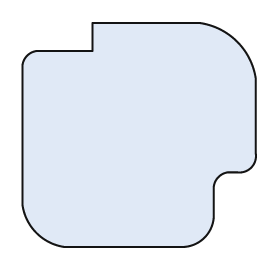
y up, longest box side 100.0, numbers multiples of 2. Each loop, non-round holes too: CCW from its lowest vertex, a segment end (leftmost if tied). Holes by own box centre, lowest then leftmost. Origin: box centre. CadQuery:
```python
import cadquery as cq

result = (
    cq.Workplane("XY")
    .moveTo(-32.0, -48.0)
    .lineTo(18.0, -48.0)
    .threePointArc((28.0, -44.0), (32.0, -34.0))
    .lineTo(32.0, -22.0)
    .threePointArc((34.0, -18.0), (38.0, -16.0))
    .lineTo(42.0, -16.0)
    .threePointArc((48.0, -14.0), (50.0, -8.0))
    .lineTo(50.0, 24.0)
    .threePointArc((42.0, 40.0), (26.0, 48.0))
    .lineTo(-20.0, 48.0)
    .lineTo(-20.0, 36.0)
    .lineTo(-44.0, 36.0)
    .threePointArc((-48.0, 34.0), (-50.0, 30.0))
    .lineTo(-50.0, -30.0)
    .threePointArc((-44.0, -42.0), (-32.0, -48.0))
    .close()
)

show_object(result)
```